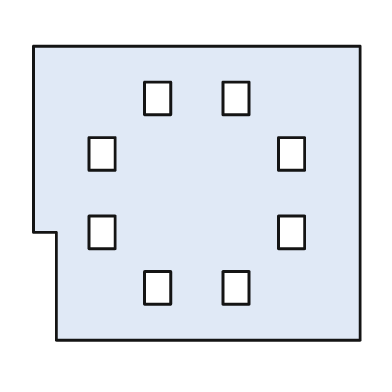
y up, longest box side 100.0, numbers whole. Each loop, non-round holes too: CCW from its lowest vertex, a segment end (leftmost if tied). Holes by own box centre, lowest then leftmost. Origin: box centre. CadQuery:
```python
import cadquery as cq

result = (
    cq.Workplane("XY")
    .moveTo(-43.0, -45.0)
    .lineTo(50.0, -45.0)
    .lineTo(50.0, 45.0)
    .lineTo(-50.0, 45.0)
    .lineTo(-50.0, -12.0)
    .lineTo(-43.0, -12.0)
    .close()
    .moveTo(-16.0, -34.0)
    .lineTo(-8.0, -34.0)
    .lineTo(-8.0, -24.0)
    .lineTo(-16.0, -24.0)
    .close()
    .moveTo(8.0, -34.0)
    .lineTo(16.0, -34.0)
    .lineTo(16.0, -24.0)
    .lineTo(8.0, -24.0)
    .close()
    .moveTo(-33.0, -17.0)
    .lineTo(-25.0, -17.0)
    .lineTo(-25.0, -7.0)
    .lineTo(-33.0, -7.0)
    .close()
    .moveTo(25.0, -17.0)
    .lineTo(33.0, -17.0)
    .lineTo(33.0, -7.0)
    .lineTo(25.0, -7.0)
    .close()
    .moveTo(-33.0, 7.0)
    .lineTo(-25.0, 7.0)
    .lineTo(-25.0, 17.0)
    .lineTo(-33.0, 17.0)
    .close()
    .moveTo(25.0, 7.0)
    .lineTo(33.0, 7.0)
    .lineTo(33.0, 17.0)
    .lineTo(25.0, 17.0)
    .close()
    .moveTo(-16.0, 24.0)
    .lineTo(-8.0, 24.0)
    .lineTo(-8.0, 34.0)
    .lineTo(-16.0, 34.0)
    .close()
    .moveTo(8.0, 24.0)
    .lineTo(16.0, 24.0)
    .lineTo(16.0, 34.0)
    .lineTo(8.0, 34.0)
    .close()
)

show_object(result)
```